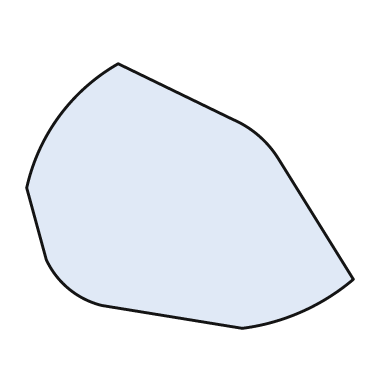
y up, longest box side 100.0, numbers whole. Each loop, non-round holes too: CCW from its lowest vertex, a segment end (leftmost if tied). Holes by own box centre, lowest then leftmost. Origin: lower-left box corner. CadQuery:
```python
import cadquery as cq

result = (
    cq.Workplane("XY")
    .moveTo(66.0, 0.0)
    .threePointArc((84.0, 5.0), (100.0, 15.0))
    .lineTo(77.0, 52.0)
    .threePointArc((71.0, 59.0), (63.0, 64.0))
    .lineTo(28.0, 81.0)
    .threePointArc((10.0, 65.0), (0.0, 43.0))
    .lineTo(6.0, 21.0)
    .threePointArc((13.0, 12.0), (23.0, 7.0))
    .close()
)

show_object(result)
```